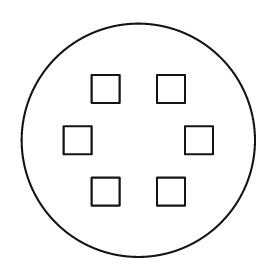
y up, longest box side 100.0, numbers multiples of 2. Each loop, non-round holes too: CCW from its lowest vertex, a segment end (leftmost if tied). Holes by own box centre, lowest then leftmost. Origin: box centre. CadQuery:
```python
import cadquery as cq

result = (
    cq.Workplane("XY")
    .moveTo(0.0, 0.0)
    .circle(50.0)
    .moveTo(-20.0, -28.0)
    .lineTo(-8.0, -28.0)
    .lineTo(-8.0, -16.0)
    .lineTo(-20.0, -16.0)
    .close()
    .moveTo(8.0, -28.0)
    .lineTo(20.0, -28.0)
    .lineTo(20.0, -16.0)
    .lineTo(8.0, -16.0)
    .close()
    .moveTo(-32.0, -6.0)
    .lineTo(-20.0, -6.0)
    .lineTo(-20.0, 6.0)
    .lineTo(-32.0, 6.0)
    .close()
    .moveTo(20.0, -6.0)
    .lineTo(32.0, -6.0)
    .lineTo(32.0, 6.0)
    .lineTo(20.0, 6.0)
    .close()
    .moveTo(-20.0, 16.0)
    .lineTo(-8.0, 16.0)
    .lineTo(-8.0, 28.0)
    .lineTo(-20.0, 28.0)
    .close()
    .moveTo(8.0, 16.0)
    .lineTo(20.0, 16.0)
    .lineTo(20.0, 28.0)
    .lineTo(8.0, 28.0)
    .close()
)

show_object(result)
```